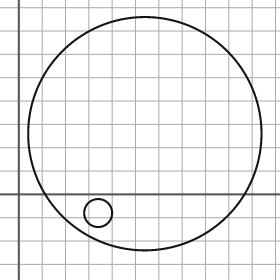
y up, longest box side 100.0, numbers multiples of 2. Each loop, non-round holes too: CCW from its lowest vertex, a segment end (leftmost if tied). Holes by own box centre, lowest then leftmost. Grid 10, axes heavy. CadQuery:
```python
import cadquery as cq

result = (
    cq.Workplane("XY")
    .moveTo(54.0, 26.0)
    .circle(50.0)
    .moveTo(34.0, -8.0)
    .circle(6.0)
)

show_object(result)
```